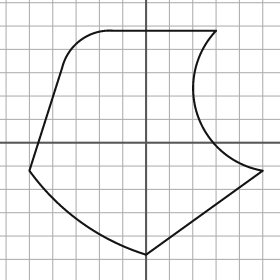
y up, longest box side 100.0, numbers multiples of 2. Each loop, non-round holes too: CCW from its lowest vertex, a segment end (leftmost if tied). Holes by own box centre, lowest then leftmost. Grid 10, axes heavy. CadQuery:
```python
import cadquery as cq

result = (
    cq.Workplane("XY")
    .moveTo(0.0, -48.0)
    .lineTo(50.0, -12.0)
    .threePointArc((22.0, 12.0), (30.0, 48.0))
    .lineTo(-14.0, 48.0)
    .threePointArc((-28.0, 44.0), (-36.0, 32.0))
    .lineTo(-50.0, -12.0)
    .threePointArc((-28.0, -34.0), (0.0, -48.0))
    .close()
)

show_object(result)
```